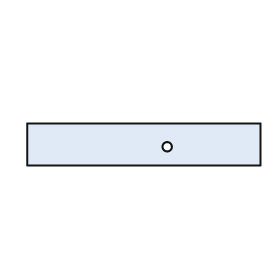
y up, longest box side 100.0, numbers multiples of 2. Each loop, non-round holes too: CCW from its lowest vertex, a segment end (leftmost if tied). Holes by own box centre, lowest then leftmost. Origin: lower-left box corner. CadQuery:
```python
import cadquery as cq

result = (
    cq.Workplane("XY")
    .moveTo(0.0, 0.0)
    .lineTo(100.0, 0.0)
    .lineTo(100.0, 18.0)
    .lineTo(0.0, 18.0)
    .close()
    .moveTo(60.0, 8.0)
    .circle(2.0)
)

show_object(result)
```